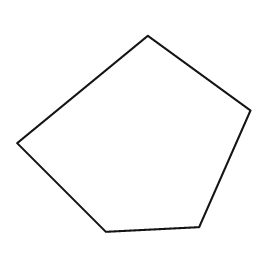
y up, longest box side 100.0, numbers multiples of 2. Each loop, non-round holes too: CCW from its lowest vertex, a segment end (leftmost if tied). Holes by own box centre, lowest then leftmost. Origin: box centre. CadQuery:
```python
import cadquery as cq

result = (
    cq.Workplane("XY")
    .moveTo(-12.0, -42.0)
    .lineTo(28.0, -40.0)
    .lineTo(50.0, 10.0)
    .lineTo(6.0, 42.0)
    .lineTo(-50.0, -4.0)
    .close()
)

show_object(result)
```